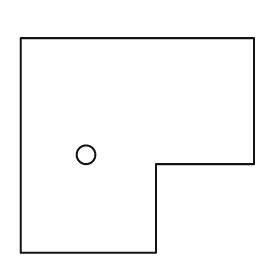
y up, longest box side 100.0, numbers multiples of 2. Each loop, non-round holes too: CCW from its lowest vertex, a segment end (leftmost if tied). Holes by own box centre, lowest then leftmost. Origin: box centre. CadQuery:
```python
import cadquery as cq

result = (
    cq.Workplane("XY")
    .moveTo(-50.0, -46.0)
    .lineTo(8.0, -46.0)
    .lineTo(8.0, -8.0)
    .lineTo(50.0, -8.0)
    .lineTo(50.0, 46.0)
    .lineTo(-50.0, 46.0)
    .close()
    .moveTo(-22.0, -4.0)
    .circle(4.0)
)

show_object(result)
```